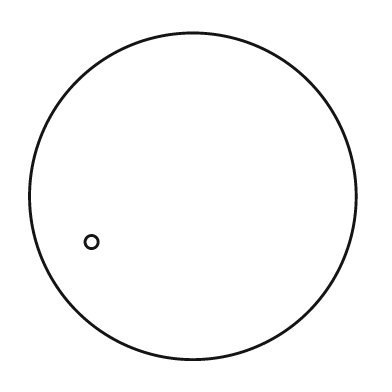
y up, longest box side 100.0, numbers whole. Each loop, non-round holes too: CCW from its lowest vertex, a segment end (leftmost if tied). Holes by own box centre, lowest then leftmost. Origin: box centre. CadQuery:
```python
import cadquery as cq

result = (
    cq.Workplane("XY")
    .moveTo(0.0, 0.0)
    .circle(50.0)
    .moveTo(-31.0, -14.0)
    .circle(2.0)
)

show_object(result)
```